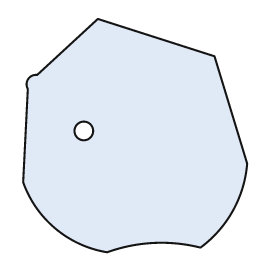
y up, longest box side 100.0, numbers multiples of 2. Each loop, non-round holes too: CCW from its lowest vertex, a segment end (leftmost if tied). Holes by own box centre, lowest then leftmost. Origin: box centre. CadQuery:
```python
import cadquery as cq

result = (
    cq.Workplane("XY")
    .moveTo(-12.0, -50.0)
    .threePointArc((8.0, -46.0), (28.0, -48.0))
    .threePointArc((42.0, -32.0), (48.0, -12.0))
    .lineTo(34.0, 34.0)
    .lineTo(-16.0, 50.0)
    .lineTo(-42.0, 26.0)
    .threePointArc((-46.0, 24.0), (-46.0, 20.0))
    .lineTo(-48.0, -20.0)
    .threePointArc((-34.0, -40.0), (-12.0, -50.0))
    .close()
    .moveTo(-22.0, 2.0)
    .circle(4.0)
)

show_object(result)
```